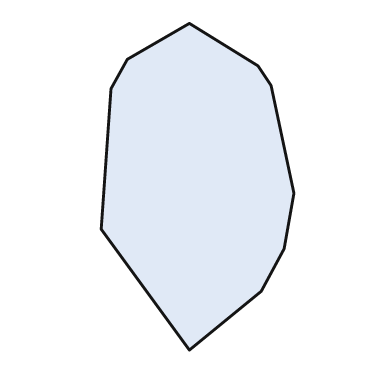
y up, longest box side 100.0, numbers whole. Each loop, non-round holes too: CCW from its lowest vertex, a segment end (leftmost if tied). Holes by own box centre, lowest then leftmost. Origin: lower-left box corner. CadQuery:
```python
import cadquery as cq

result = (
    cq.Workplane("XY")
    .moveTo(27.0, 0.0)
    .lineTo(49.0, 18.0)
    .lineTo(56.0, 31.0)
    .lineTo(59.0, 48.0)
    .lineTo(52.0, 81.0)
    .lineTo(48.0, 87.0)
    .lineTo(27.0, 100.0)
    .lineTo(8.0, 89.0)
    .lineTo(3.0, 80.0)
    .lineTo(0.0, 37.0)
    .close()
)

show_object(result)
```